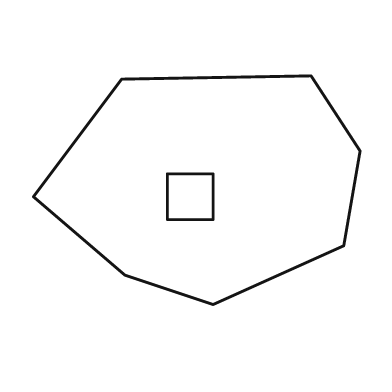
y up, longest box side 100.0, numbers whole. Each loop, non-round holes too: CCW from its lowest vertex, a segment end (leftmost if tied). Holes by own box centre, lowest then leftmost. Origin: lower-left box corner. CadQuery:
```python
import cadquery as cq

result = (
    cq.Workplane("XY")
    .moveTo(55.0, 0.0)
    .lineTo(95.0, 18.0)
    .lineTo(100.0, 47.0)
    .lineTo(85.0, 70.0)
    .lineTo(27.0, 69.0)
    .lineTo(0.0, 33.0)
    .lineTo(28.0, 9.0)
    .close()
    .moveTo(41.0, 26.0)
    .lineTo(55.0, 26.0)
    .lineTo(55.0, 40.0)
    .lineTo(41.0, 40.0)
    .close()
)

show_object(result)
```